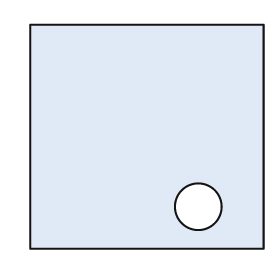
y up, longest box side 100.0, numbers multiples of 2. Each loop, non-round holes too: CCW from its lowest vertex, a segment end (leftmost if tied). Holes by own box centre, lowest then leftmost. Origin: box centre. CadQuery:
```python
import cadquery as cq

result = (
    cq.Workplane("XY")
    .moveTo(-50.0, -48.0)
    .lineTo(50.0, -48.0)
    .lineTo(50.0, 48.0)
    .lineTo(-50.0, 48.0)
    .close()
    .moveTo(22.0, -30.0)
    .circle(10.0)
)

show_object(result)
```